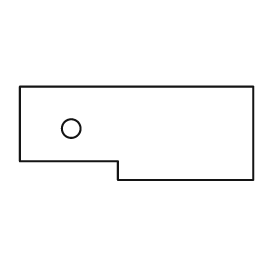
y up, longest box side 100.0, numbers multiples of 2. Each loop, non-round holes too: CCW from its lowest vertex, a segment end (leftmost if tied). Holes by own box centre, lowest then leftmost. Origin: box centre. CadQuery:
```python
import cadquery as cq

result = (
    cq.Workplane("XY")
    .moveTo(-8.0, -20.0)
    .lineTo(50.0, -20.0)
    .lineTo(50.0, 20.0)
    .lineTo(-50.0, 20.0)
    .lineTo(-50.0, -12.0)
    .lineTo(-8.0, -12.0)
    .close()
    .moveTo(-28.0, 2.0)
    .circle(4.0)
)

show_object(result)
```